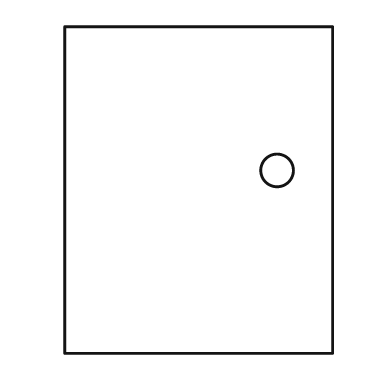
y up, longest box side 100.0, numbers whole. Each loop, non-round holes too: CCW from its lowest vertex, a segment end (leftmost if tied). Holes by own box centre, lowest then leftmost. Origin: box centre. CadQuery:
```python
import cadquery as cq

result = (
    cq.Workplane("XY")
    .moveTo(-41.0, -50.0)
    .lineTo(41.0, -50.0)
    .lineTo(41.0, 50.0)
    .lineTo(-41.0, 50.0)
    .close()
    .moveTo(24.0, 6.0)
    .circle(5.0)
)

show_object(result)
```